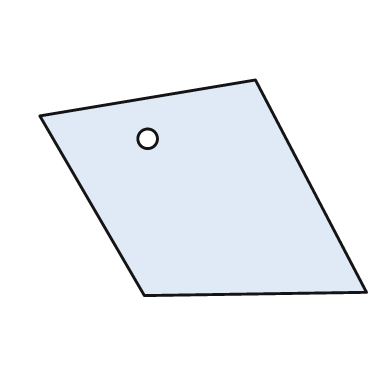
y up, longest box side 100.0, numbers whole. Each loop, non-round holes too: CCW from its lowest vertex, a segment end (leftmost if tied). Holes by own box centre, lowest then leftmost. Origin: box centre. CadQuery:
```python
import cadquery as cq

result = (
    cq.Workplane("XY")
    .moveTo(-18.0, -33.0)
    .lineTo(50.0, -32.0)
    .lineTo(16.0, 33.0)
    .lineTo(-50.0, 22.0)
    .close()
    .moveTo(-17.0, 15.0)
    .circle(3.0)
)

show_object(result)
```